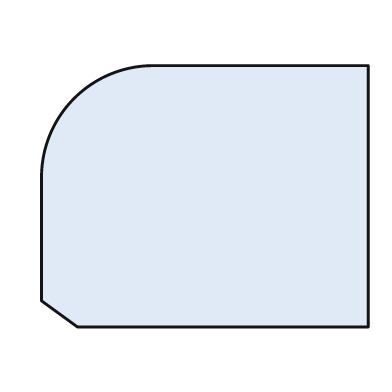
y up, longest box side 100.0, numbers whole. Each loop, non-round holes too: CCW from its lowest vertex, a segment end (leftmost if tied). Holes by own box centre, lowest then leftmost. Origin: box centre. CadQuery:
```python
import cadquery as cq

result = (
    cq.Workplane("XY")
    .moveTo(-39.0, -40.0)
    .lineTo(50.0, -40.0)
    .lineTo(50.0, 40.0)
    .lineTo(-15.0, 40.0)
    .threePointArc((-40.0, 30.0), (-50.0, 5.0))
    .lineTo(-50.0, -32.0)
    .close()
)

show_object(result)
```